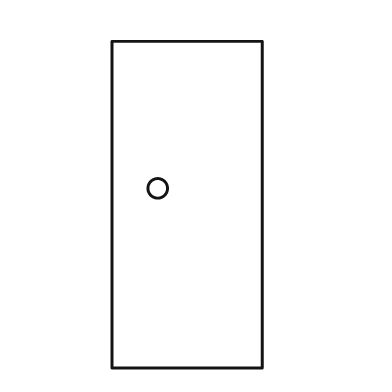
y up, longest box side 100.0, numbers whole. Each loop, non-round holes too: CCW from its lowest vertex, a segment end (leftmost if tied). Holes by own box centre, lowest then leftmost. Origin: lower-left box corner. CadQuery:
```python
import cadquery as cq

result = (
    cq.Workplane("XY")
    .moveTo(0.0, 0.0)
    .lineTo(46.0, 0.0)
    .lineTo(46.0, 100.0)
    .lineTo(0.0, 100.0)
    .close()
    .moveTo(14.0, 55.0)
    .circle(3.0)
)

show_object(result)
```